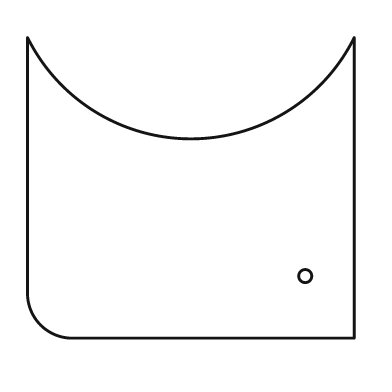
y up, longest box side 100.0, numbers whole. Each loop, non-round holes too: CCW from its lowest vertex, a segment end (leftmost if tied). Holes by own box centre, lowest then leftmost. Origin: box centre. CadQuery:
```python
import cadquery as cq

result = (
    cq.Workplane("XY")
    .moveTo(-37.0, -46.0)
    .lineTo(50.0, -46.0)
    .lineTo(50.0, 46.0)
    .threePointArc((0.0, 15.0), (-50.0, 46.0))
    .lineTo(-50.0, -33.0)
    .threePointArc((-46.0, -42.0), (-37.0, -46.0))
    .close()
    .moveTo(35.0, -27.0)
    .circle(2.0)
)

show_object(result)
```